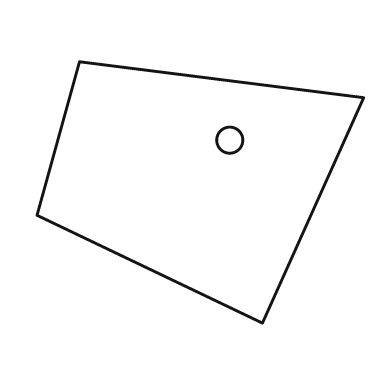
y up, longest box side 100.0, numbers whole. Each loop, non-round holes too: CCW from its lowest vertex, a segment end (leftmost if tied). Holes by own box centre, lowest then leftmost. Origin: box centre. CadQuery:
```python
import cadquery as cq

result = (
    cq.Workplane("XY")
    .moveTo(19.0, -40.0)
    .lineTo(50.0, 29.0)
    .lineTo(-37.0, 40.0)
    .lineTo(-50.0, -7.0)
    .close()
    .moveTo(9.0, 16.0)
    .circle(4.0)
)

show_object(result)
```